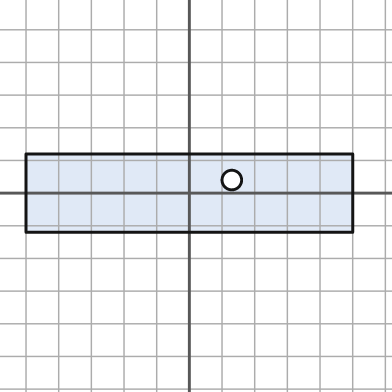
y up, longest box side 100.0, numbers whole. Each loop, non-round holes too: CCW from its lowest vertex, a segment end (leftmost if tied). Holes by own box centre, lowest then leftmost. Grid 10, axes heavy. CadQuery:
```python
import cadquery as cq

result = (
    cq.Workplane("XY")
    .moveTo(-50.0, -12.0)
    .lineTo(50.0, -12.0)
    .lineTo(50.0, 12.0)
    .lineTo(-50.0, 12.0)
    .close()
    .moveTo(13.0, 4.0)
    .circle(3.0)
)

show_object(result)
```